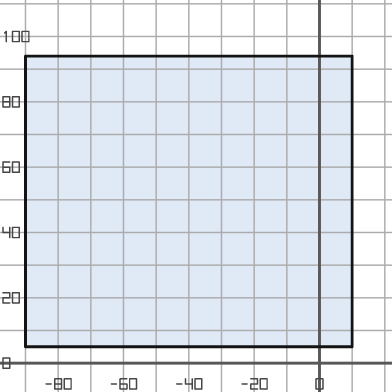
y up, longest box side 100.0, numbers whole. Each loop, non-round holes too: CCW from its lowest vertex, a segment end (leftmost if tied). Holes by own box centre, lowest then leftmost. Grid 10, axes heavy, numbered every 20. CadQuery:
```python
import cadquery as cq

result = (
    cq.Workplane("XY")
    .moveTo(-90.0, 5.0)
    .lineTo(10.0, 5.0)
    .lineTo(10.0, 94.0)
    .lineTo(-90.0, 94.0)
    .close()
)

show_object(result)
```